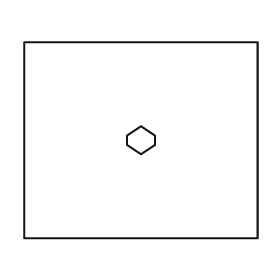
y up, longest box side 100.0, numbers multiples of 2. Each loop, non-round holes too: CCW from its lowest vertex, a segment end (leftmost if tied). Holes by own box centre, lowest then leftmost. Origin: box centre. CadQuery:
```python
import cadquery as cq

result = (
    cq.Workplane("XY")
    .moveTo(-50.0, -42.0)
    .lineTo(50.0, -42.0)
    .lineTo(50.0, 42.0)
    .lineTo(-50.0, 42.0)
    .close()
    .moveTo(0.0, -6.0)
    .lineTo(6.0, -2.0)
    .lineTo(6.0, 2.0)
    .lineTo(0.0, 6.0)
    .lineTo(-6.0, 2.0)
    .lineTo(-6.0, -2.0)
    .close()
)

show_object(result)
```